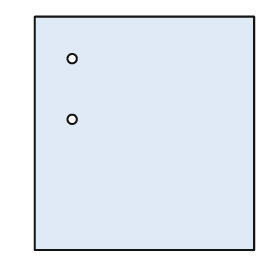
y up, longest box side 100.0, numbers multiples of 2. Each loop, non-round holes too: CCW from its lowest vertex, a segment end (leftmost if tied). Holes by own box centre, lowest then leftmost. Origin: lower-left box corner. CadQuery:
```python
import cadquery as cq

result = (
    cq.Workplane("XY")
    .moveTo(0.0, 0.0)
    .lineTo(94.0, 0.0)
    .lineTo(94.0, 100.0)
    .lineTo(0.0, 100.0)
    .close()
    .moveTo(16.0, 56.0)
    .circle(2.0)
    .moveTo(16.0, 82.0)
    .circle(2.0)
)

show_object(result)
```